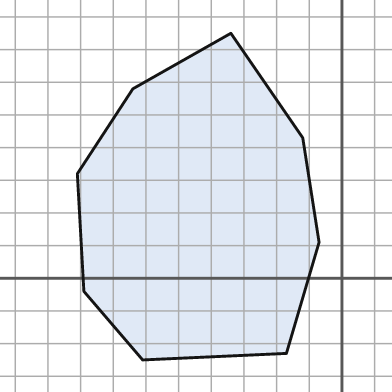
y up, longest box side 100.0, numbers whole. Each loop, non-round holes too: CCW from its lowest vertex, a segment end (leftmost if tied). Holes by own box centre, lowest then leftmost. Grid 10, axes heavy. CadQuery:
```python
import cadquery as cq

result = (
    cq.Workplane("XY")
    .moveTo(-61.0, -25.0)
    .lineTo(-17.0, -23.0)
    .lineTo(-7.0, 11.0)
    .lineTo(-12.0, 43.0)
    .lineTo(-34.0, 75.0)
    .lineTo(-64.0, 58.0)
    .lineTo(-81.0, 32.0)
    .lineTo(-79.0, -4.0)
    .close()
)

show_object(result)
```